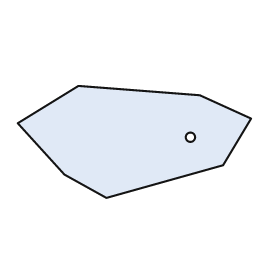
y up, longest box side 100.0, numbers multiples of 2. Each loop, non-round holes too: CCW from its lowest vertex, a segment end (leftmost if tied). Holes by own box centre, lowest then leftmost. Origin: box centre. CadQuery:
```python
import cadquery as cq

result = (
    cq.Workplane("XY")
    .moveTo(-12.0, -24.0)
    .lineTo(38.0, -10.0)
    .lineTo(50.0, 10.0)
    .lineTo(28.0, 20.0)
    .lineTo(-24.0, 24.0)
    .lineTo(-50.0, 8.0)
    .lineTo(-30.0, -14.0)
    .close()
    .moveTo(24.0, 2.0)
    .circle(2.0)
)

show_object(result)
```